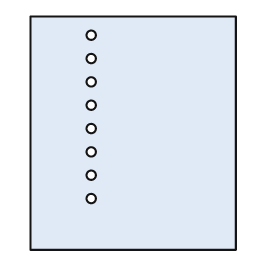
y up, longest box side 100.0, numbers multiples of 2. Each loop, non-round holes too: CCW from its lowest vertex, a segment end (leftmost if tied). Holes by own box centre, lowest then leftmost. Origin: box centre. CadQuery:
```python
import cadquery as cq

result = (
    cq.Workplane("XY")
    .moveTo(-44.0, -50.0)
    .lineTo(44.0, -50.0)
    .lineTo(44.0, 50.0)
    .lineTo(-44.0, 50.0)
    .close()
    .moveTo(-18.0, -28.0)
    .circle(2.0)
    .moveTo(-18.0, -18.0)
    .circle(2.0)
    .moveTo(-18.0, -8.0)
    .circle(2.0)
    .moveTo(-18.0, 2.0)
    .circle(2.0)
    .moveTo(-18.0, 12.0)
    .circle(2.0)
    .moveTo(-18.0, 22.0)
    .circle(2.0)
    .moveTo(-18.0, 32.0)
    .circle(2.0)
    .moveTo(-18.0, 42.0)
    .circle(2.0)
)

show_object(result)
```